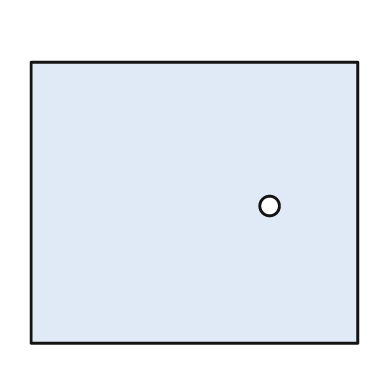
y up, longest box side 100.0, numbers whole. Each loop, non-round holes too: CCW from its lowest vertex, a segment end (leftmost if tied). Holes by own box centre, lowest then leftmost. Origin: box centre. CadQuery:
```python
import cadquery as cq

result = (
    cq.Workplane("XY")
    .moveTo(-50.0, -43.0)
    .lineTo(50.0, -43.0)
    .lineTo(50.0, 43.0)
    .lineTo(-50.0, 43.0)
    .close()
    .moveTo(23.0, -1.0)
    .circle(3.0)
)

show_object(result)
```